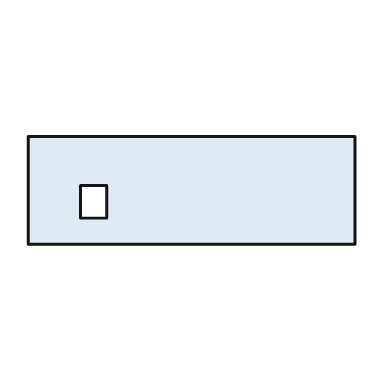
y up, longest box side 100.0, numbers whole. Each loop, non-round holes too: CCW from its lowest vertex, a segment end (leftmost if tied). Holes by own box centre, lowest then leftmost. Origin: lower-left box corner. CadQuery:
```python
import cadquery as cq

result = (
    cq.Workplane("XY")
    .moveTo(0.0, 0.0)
    .lineTo(100.0, 0.0)
    .lineTo(100.0, 33.0)
    .lineTo(0.0, 33.0)
    .close()
    .moveTo(16.0, 8.0)
    .lineTo(24.0, 8.0)
    .lineTo(24.0, 18.0)
    .lineTo(16.0, 18.0)
    .close()
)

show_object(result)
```